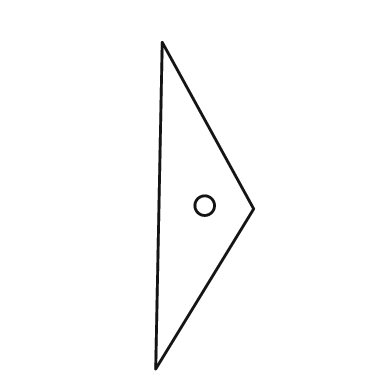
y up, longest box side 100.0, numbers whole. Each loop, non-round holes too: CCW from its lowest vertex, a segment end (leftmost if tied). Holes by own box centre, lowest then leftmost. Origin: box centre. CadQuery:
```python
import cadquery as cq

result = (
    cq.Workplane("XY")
    .moveTo(-15.0, -50.0)
    .lineTo(15.0, -1.0)
    .lineTo(-13.0, 50.0)
    .close()
    .moveTo(0.0, 0.0)
    .circle(3.0)
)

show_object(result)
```